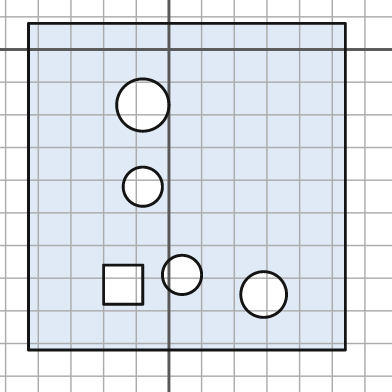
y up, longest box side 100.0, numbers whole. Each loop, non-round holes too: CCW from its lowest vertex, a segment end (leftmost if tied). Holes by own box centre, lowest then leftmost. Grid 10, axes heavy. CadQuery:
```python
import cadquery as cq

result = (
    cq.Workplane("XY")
    .moveTo(-43.0, -92.0)
    .lineTo(54.0, -92.0)
    .lineTo(54.0, 8.0)
    .lineTo(-43.0, 8.0)
    .close()
    .moveTo(29.0, -75.0)
    .circle(7.0)
    .moveTo(-20.0, -78.0)
    .lineTo(-8.0, -78.0)
    .lineTo(-8.0, -66.0)
    .lineTo(-20.0, -66.0)
    .close()
    .moveTo(4.0, -69.0)
    .circle(6.0)
    .moveTo(-8.0, -42.0)
    .circle(6.0)
    .moveTo(-8.0, -17.0)
    .circle(8.0)
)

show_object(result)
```